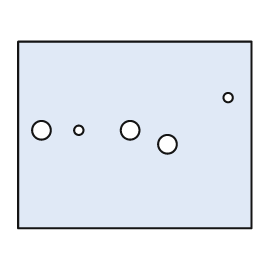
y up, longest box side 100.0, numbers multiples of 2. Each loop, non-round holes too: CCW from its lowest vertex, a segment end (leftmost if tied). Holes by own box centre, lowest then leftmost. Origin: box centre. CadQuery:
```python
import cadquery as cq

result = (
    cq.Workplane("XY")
    .moveTo(-50.0, -40.0)
    .lineTo(50.0, -40.0)
    .lineTo(50.0, 40.0)
    .lineTo(-50.0, 40.0)
    .close()
    .moveTo(14.0, -4.0)
    .circle(4.0)
    .moveTo(-40.0, 2.0)
    .circle(4.0)
    .moveTo(-24.0, 2.0)
    .circle(2.0)
    .moveTo(-2.0, 2.0)
    .circle(4.0)
    .moveTo(40.0, 16.0)
    .circle(2.0)
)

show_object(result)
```